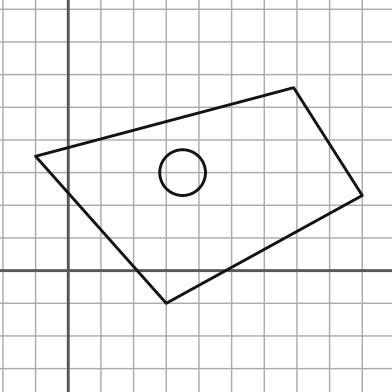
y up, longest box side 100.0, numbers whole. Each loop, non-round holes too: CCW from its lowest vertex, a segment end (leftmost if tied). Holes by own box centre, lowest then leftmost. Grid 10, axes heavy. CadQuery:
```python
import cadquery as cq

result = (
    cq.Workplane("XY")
    .moveTo(30.0, -10.0)
    .lineTo(90.0, 23.0)
    .lineTo(69.0, 56.0)
    .lineTo(-10.0, 35.0)
    .close()
    .moveTo(35.0, 30.0)
    .circle(7.0)
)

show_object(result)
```